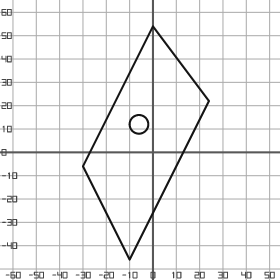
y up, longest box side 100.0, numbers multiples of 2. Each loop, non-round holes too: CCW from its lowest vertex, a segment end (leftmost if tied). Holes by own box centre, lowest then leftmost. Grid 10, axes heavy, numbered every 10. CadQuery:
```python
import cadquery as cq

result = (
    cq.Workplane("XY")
    .moveTo(-10.0, -46.0)
    .lineTo(24.0, 22.0)
    .lineTo(0.0, 54.0)
    .lineTo(-30.0, -6.0)
    .close()
    .moveTo(-6.0, 12.0)
    .circle(4.0)
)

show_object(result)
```